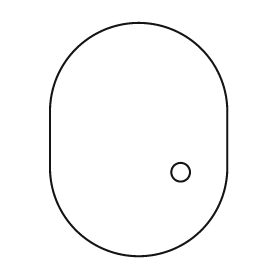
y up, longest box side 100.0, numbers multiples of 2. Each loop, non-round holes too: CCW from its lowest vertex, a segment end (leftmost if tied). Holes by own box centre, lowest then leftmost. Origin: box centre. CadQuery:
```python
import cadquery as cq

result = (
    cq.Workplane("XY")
    .moveTo(-38.0, -12.0)
    .threePointArc((0.0, -50.0), (38.0, -12.0))
    .lineTo(38.0, 12.0)
    .threePointArc((0.0, 50.0), (-38.0, 12.0))
    .close()
    .moveTo(18.0, -14.0)
    .circle(4.0)
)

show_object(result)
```